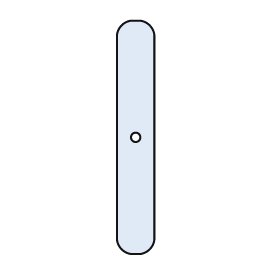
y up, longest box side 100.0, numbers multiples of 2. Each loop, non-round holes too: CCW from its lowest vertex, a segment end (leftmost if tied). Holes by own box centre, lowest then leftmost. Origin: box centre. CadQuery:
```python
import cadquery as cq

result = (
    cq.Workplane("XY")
    .moveTo(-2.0, -50.0)
    .lineTo(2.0, -50.0)
    .threePointArc((6.0, -48.0), (8.0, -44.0))
    .lineTo(8.0, 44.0)
    .threePointArc((6.0, 48.0), (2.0, 50.0))
    .lineTo(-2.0, 50.0)
    .threePointArc((-6.0, 48.0), (-8.0, 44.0))
    .lineTo(-8.0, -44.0)
    .threePointArc((-6.0, -48.0), (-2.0, -50.0))
    .close()
    .moveTo(0.0, 0.0)
    .circle(2.0)
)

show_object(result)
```